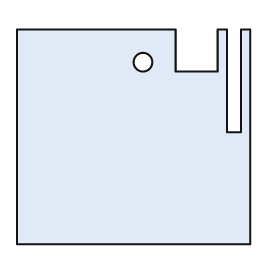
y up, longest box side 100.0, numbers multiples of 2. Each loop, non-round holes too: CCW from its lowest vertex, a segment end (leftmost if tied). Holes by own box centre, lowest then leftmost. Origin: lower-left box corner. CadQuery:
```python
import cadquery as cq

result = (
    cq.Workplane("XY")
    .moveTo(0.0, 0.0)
    .lineTo(100.0, 0.0)
    .lineTo(100.0, 92.0)
    .lineTo(96.0, 92.0)
    .lineTo(96.0, 48.0)
    .lineTo(90.0, 48.0)
    .lineTo(90.0, 92.0)
    .lineTo(86.0, 92.0)
    .lineTo(86.0, 74.0)
    .lineTo(68.0, 74.0)
    .lineTo(68.0, 92.0)
    .lineTo(0.0, 92.0)
    .close()
    .moveTo(54.0, 78.0)
    .circle(4.0)
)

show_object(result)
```